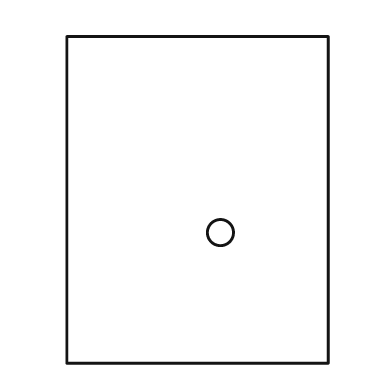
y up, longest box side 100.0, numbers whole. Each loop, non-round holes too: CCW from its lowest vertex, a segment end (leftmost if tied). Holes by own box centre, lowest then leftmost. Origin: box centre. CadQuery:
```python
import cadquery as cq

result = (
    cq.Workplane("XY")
    .moveTo(-40.0, -50.0)
    .lineTo(40.0, -50.0)
    .lineTo(40.0, 50.0)
    .lineTo(-40.0, 50.0)
    .close()
    .moveTo(7.0, -10.0)
    .circle(4.0)
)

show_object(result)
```